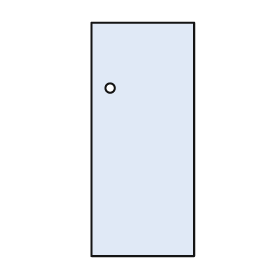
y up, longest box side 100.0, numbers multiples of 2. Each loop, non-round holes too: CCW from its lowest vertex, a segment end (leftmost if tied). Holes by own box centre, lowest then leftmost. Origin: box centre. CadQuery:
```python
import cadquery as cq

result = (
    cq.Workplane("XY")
    .moveTo(-22.0, -50.0)
    .lineTo(22.0, -50.0)
    .lineTo(22.0, 50.0)
    .lineTo(-22.0, 50.0)
    .close()
    .moveTo(-14.0, 22.0)
    .circle(2.0)
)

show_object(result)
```